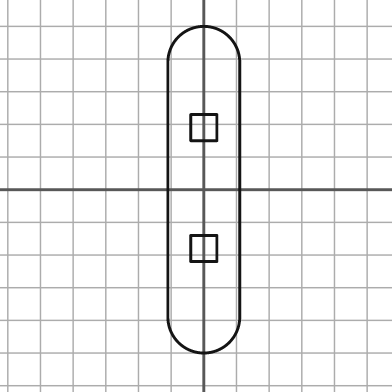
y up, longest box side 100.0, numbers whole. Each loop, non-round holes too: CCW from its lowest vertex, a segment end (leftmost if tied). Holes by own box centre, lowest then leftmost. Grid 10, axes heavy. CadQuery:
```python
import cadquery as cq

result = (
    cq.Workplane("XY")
    .moveTo(-11.0, -39.0)
    .threePointArc((0.0, -50.0), (11.0, -39.0))
    .lineTo(11.0, 39.0)
    .threePointArc((0.0, 50.0), (-11.0, 39.0))
    .close()
    .moveTo(-4.0, -22.0)
    .lineTo(4.0, -22.0)
    .lineTo(4.0, -14.0)
    .lineTo(-4.0, -14.0)
    .close()
    .moveTo(-4.0, 15.0)
    .lineTo(4.0, 15.0)
    .lineTo(4.0, 23.0)
    .lineTo(-4.0, 23.0)
    .close()
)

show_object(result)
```